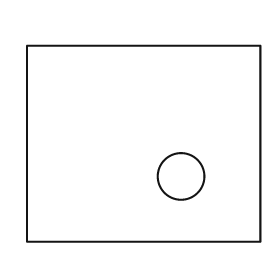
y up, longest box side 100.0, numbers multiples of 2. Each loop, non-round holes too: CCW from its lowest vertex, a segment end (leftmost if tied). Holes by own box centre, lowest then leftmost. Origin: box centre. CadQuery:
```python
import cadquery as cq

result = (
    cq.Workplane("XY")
    .moveTo(-50.0, -42.0)
    .lineTo(50.0, -42.0)
    .lineTo(50.0, 42.0)
    .lineTo(-50.0, 42.0)
    .close()
    .moveTo(16.0, -14.0)
    .circle(10.0)
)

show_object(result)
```